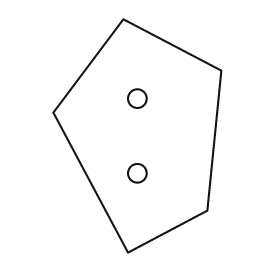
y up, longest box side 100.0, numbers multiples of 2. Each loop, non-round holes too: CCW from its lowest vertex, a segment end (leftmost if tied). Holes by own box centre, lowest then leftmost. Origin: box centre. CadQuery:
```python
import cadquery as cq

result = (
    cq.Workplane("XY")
    .moveTo(-4.0, -50.0)
    .lineTo(30.0, -32.0)
    .lineTo(36.0, 28.0)
    .lineTo(-6.0, 50.0)
    .lineTo(-36.0, 10.0)
    .close()
    .moveTo(0.0, -16.0)
    .circle(4.0)
    .moveTo(0.0, 16.0)
    .circle(4.0)
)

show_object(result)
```